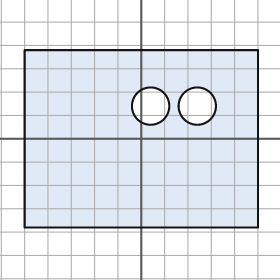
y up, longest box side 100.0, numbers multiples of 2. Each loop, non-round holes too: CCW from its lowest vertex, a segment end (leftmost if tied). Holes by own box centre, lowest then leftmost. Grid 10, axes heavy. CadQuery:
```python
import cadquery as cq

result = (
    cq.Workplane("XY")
    .moveTo(-50.0, -38.0)
    .lineTo(50.0, -38.0)
    .lineTo(50.0, 38.0)
    .lineTo(-50.0, 38.0)
    .close()
    .moveTo(4.0, 14.0)
    .circle(8.0)
    .moveTo(24.0, 14.0)
    .circle(8.0)
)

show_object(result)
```